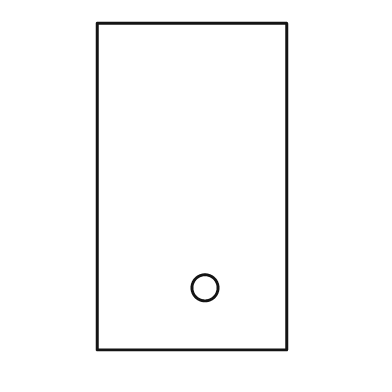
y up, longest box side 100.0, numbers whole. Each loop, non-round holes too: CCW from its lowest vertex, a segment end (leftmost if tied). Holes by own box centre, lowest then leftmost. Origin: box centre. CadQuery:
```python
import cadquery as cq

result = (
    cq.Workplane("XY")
    .moveTo(-29.0, -50.0)
    .lineTo(29.0, -50.0)
    .lineTo(29.0, 50.0)
    .lineTo(-29.0, 50.0)
    .close()
    .moveTo(4.0, -31.0)
    .circle(4.0)
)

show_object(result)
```